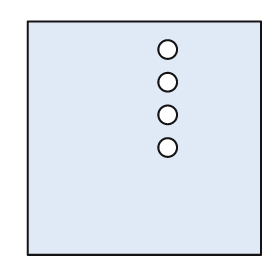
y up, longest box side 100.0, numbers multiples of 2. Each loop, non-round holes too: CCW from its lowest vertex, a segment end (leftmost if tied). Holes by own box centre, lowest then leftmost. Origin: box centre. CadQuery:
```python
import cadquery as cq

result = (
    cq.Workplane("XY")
    .moveTo(-50.0, -50.0)
    .lineTo(50.0, -50.0)
    .lineTo(50.0, 50.0)
    .lineTo(-50.0, 50.0)
    .close()
    .moveTo(10.0, -4.0)
    .circle(4.0)
    .moveTo(10.0, 10.0)
    .circle(4.0)
    .moveTo(10.0, 24.0)
    .circle(4.0)
    .moveTo(10.0, 38.0)
    .circle(4.0)
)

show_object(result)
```